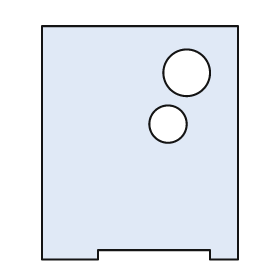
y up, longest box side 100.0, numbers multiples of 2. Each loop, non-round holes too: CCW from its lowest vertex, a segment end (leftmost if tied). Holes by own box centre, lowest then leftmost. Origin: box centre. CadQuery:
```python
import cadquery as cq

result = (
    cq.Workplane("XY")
    .moveTo(-42.0, -50.0)
    .lineTo(-18.0, -50.0)
    .lineTo(-18.0, -46.0)
    .lineTo(30.0, -46.0)
    .lineTo(30.0, -50.0)
    .lineTo(42.0, -50.0)
    .lineTo(42.0, 50.0)
    .lineTo(-42.0, 50.0)
    .close()
    .moveTo(12.0, 8.0)
    .circle(8.0)
    .moveTo(20.0, 30.0)
    .circle(10.0)
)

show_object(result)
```